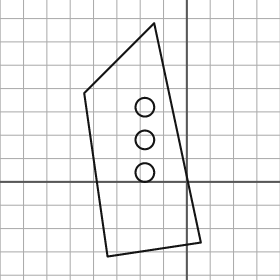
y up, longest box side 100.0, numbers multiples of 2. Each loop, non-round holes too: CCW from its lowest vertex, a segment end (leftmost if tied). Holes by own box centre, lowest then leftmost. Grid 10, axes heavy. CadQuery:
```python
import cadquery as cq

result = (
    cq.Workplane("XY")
    .moveTo(-34.0, -32.0)
    .lineTo(6.0, -26.0)
    .lineTo(-14.0, 68.0)
    .lineTo(-44.0, 38.0)
    .close()
    .moveTo(-18.0, 4.0)
    .circle(4.0)
    .moveTo(-18.0, 18.0)
    .circle(4.0)
    .moveTo(-18.0, 32.0)
    .circle(4.0)
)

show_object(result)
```